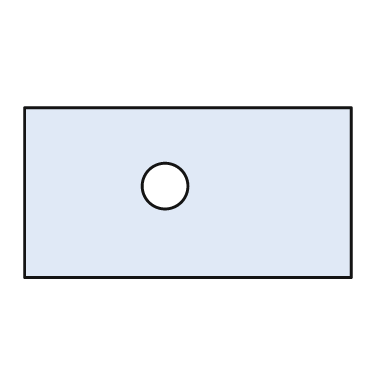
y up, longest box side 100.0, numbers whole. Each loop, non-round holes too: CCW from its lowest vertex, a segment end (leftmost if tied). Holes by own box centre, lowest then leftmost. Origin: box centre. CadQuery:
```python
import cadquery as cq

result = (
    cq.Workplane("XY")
    .moveTo(-50.0, -26.0)
    .lineTo(50.0, -26.0)
    .lineTo(50.0, 26.0)
    .lineTo(-50.0, 26.0)
    .close()
    .moveTo(-7.0, 2.0)
    .circle(7.0)
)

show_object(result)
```